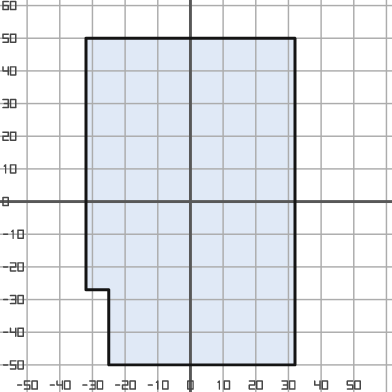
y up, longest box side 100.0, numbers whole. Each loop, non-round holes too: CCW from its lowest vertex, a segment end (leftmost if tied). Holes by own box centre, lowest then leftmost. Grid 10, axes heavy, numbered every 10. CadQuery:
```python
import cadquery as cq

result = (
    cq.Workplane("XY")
    .moveTo(-25.0, -50.0)
    .lineTo(32.0, -50.0)
    .lineTo(32.0, 50.0)
    .lineTo(-32.0, 50.0)
    .lineTo(-32.0, -27.0)
    .lineTo(-25.0, -27.0)
    .close()
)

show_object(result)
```